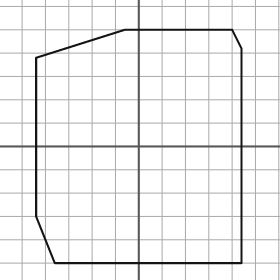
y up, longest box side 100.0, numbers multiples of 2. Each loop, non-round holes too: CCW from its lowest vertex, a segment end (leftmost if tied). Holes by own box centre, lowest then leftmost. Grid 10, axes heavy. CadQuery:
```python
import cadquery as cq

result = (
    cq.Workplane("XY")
    .moveTo(-36.0, -50.0)
    .lineTo(44.0, -50.0)
    .lineTo(44.0, 42.0)
    .lineTo(40.0, 50.0)
    .lineTo(-6.0, 50.0)
    .lineTo(-44.0, 38.0)
    .lineTo(-44.0, -30.0)
    .close()
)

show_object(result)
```